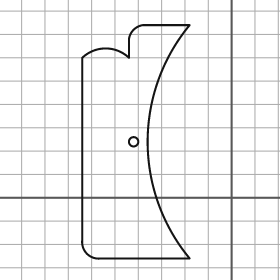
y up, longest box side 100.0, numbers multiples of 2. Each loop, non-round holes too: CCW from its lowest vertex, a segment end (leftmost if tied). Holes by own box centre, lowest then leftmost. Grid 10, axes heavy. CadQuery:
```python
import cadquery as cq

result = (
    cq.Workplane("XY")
    .moveTo(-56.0, -26.0)
    .lineTo(-18.0, -26.0)
    .threePointArc((-36.0, 24.0), (-18.0, 74.0))
    .lineTo(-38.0, 74.0)
    .threePointArc((-42.0, 72.0), (-44.0, 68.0))
    .lineTo(-44.0, 60.0)
    .threePointArc((-54.0, 64.0), (-64.0, 60.0))
    .lineTo(-64.0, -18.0)
    .threePointArc((-62.0, -24.0), (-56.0, -26.0))
    .close()
    .moveTo(-42.0, 24.0)
    .circle(2.0)
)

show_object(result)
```